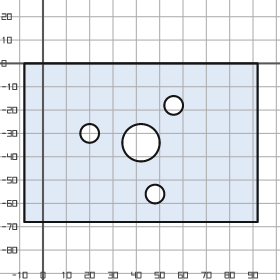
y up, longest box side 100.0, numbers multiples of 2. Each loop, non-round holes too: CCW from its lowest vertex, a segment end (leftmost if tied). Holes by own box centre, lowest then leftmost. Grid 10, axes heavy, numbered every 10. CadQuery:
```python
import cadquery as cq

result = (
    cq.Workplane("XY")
    .moveTo(-8.0, -68.0)
    .lineTo(92.0, -68.0)
    .lineTo(92.0, 0.0)
    .lineTo(-8.0, 0.0)
    .close()
    .moveTo(48.0, -56.0)
    .circle(4.0)
    .moveTo(42.0, -34.0)
    .circle(8.0)
    .moveTo(20.0, -30.0)
    .circle(4.0)
    .moveTo(56.0, -18.0)
    .circle(4.0)
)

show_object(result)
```